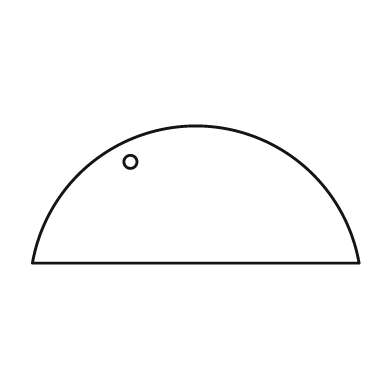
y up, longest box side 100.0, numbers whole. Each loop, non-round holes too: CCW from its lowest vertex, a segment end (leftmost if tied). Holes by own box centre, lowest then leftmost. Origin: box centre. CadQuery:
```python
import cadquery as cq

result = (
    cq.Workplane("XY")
    .moveTo(-50.0, -21.0)
    .lineTo(50.0, -21.0)
    .threePointArc((0.0, 21.0), (-50.0, -21.0))
    .close()
    .moveTo(-20.0, 10.0)
    .circle(2.0)
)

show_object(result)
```